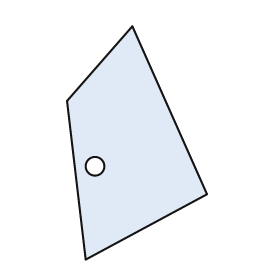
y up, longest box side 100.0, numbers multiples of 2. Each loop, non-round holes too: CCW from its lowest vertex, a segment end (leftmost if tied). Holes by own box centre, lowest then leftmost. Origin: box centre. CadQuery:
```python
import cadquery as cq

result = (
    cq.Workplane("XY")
    .moveTo(-22.0, -50.0)
    .lineTo(30.0, -22.0)
    .lineTo(-2.0, 50.0)
    .lineTo(-30.0, 18.0)
    .close()
    .moveTo(-18.0, -10.0)
    .circle(4.0)
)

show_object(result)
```